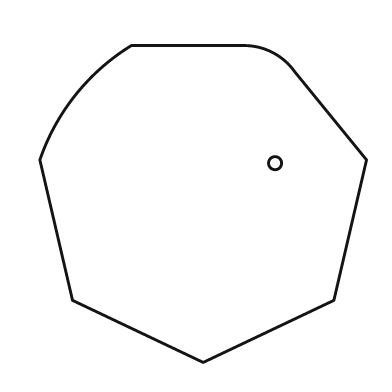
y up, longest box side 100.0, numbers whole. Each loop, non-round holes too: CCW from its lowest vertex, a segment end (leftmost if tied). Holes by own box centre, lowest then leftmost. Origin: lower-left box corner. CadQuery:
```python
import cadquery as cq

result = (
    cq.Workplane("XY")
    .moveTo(50.0, 0.0)
    .lineTo(90.0, 19.0)
    .lineTo(100.0, 62.0)
    .lineTo(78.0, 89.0)
    .threePointArc((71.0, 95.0), (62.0, 97.0))
    .lineTo(28.0, 97.0)
    .threePointArc((11.0, 82.0), (0.0, 62.0))
    .lineTo(10.0, 19.0)
    .close()
    .moveTo(72.0, 61.0)
    .circle(2.0)
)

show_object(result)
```